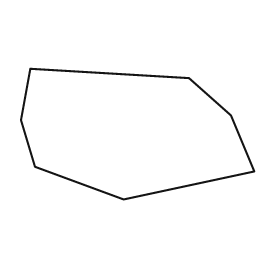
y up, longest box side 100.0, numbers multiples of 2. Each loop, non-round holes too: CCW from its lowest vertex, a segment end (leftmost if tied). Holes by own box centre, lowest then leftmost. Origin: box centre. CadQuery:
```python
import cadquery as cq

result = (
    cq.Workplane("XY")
    .moveTo(-6.0, -28.0)
    .lineTo(50.0, -16.0)
    .lineTo(40.0, 8.0)
    .lineTo(22.0, 24.0)
    .lineTo(-46.0, 28.0)
    .lineTo(-50.0, 6.0)
    .lineTo(-44.0, -14.0)
    .close()
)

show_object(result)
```